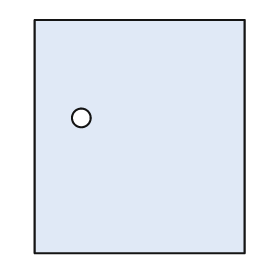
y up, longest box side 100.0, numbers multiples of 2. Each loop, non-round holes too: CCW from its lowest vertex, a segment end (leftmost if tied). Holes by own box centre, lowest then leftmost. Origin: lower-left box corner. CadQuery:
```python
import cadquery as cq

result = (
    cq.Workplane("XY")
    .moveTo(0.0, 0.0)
    .lineTo(90.0, 0.0)
    .lineTo(90.0, 100.0)
    .lineTo(0.0, 100.0)
    .close()
    .moveTo(20.0, 58.0)
    .circle(4.0)
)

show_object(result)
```